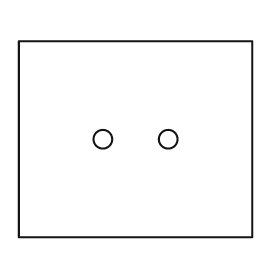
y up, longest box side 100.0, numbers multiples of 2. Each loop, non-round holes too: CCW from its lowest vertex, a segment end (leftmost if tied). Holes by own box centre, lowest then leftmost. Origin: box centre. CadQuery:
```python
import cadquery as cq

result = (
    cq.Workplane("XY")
    .moveTo(-50.0, -42.0)
    .lineTo(50.0, -42.0)
    .lineTo(50.0, 42.0)
    .lineTo(-50.0, 42.0)
    .close()
    .moveTo(-14.0, 0.0)
    .circle(4.0)
    .moveTo(14.0, 0.0)
    .circle(4.0)
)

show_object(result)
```